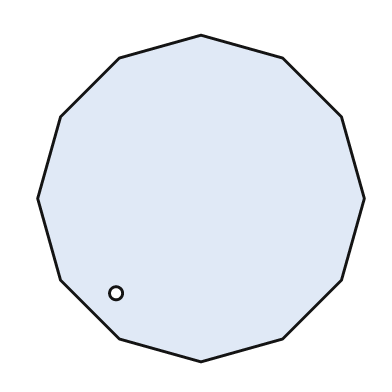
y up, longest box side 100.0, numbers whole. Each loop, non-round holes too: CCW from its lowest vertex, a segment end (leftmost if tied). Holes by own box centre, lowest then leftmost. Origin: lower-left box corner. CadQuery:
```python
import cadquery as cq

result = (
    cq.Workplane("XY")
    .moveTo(50.0, 0.0)
    .lineTo(75.0, 7.0)
    .lineTo(93.0, 25.0)
    .lineTo(100.0, 50.0)
    .lineTo(93.0, 75.0)
    .lineTo(75.0, 93.0)
    .lineTo(50.0, 100.0)
    .lineTo(25.0, 93.0)
    .lineTo(7.0, 75.0)
    .lineTo(0.0, 50.0)
    .lineTo(7.0, 25.0)
    .lineTo(25.0, 7.0)
    .close()
    .moveTo(24.0, 21.0)
    .circle(2.0)
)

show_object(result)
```